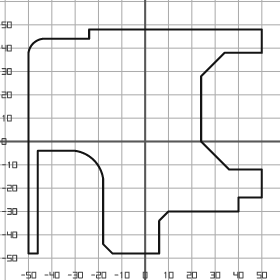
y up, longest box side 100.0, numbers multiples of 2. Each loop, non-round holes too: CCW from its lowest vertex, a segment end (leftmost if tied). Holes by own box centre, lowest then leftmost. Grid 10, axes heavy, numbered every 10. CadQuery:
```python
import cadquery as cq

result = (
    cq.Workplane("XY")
    .moveTo(-50.0, -48.0)
    .lineTo(-46.0, -48.0)
    .lineTo(-46.0, -4.0)
    .lineTo(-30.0, -4.0)
    .threePointArc((-22.0, -8.0), (-18.0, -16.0))
    .lineTo(-18.0, -44.0)
    .lineTo(-14.0, -48.0)
    .lineTo(6.0, -48.0)
    .lineTo(6.0, -34.0)
    .lineTo(10.0, -30.0)
    .lineTo(40.0, -30.0)
    .lineTo(40.0, -24.0)
    .lineTo(50.0, -24.0)
    .lineTo(50.0, -12.0)
    .lineTo(36.0, -12.0)
    .lineTo(24.0, 0.0)
    .lineTo(24.0, 28.0)
    .lineTo(34.0, 38.0)
    .lineTo(50.0, 38.0)
    .lineTo(50.0, 48.0)
    .lineTo(-24.0, 48.0)
    .lineTo(-24.0, 44.0)
    .lineTo(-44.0, 44.0)
    .threePointArc((-48.0, 42.0), (-50.0, 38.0))
    .close()
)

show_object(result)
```